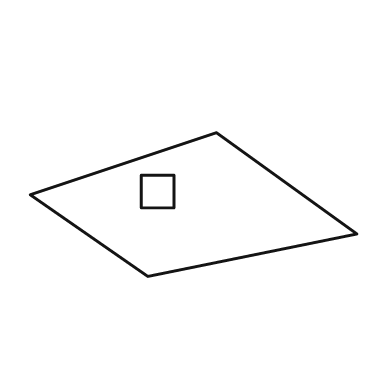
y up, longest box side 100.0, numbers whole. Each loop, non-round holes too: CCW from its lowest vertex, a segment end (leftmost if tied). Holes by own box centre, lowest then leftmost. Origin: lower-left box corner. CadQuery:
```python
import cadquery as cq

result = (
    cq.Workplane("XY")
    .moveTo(36.0, 0.0)
    .lineTo(100.0, 13.0)
    .lineTo(57.0, 44.0)
    .lineTo(0.0, 25.0)
    .close()
    .moveTo(34.0, 21.0)
    .lineTo(44.0, 21.0)
    .lineTo(44.0, 31.0)
    .lineTo(34.0, 31.0)
    .close()
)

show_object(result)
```